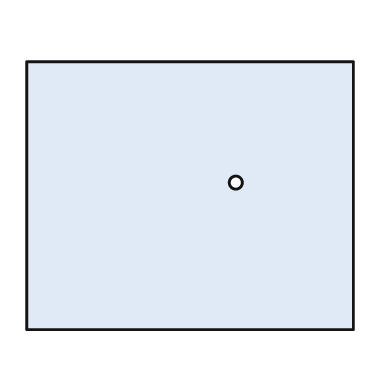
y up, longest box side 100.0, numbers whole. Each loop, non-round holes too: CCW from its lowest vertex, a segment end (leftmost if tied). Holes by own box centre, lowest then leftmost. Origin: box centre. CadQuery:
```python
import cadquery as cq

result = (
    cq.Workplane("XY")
    .moveTo(-50.0, -41.0)
    .lineTo(50.0, -41.0)
    .lineTo(50.0, 41.0)
    .lineTo(-50.0, 41.0)
    .close()
    .moveTo(14.0, 4.0)
    .circle(2.0)
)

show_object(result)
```